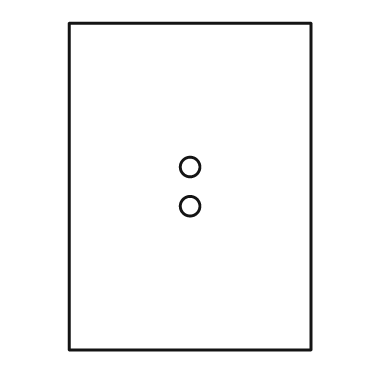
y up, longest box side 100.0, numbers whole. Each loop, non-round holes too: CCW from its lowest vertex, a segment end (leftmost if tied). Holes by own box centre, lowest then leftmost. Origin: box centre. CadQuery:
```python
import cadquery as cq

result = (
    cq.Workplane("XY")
    .moveTo(-37.0, -50.0)
    .lineTo(37.0, -50.0)
    .lineTo(37.0, 50.0)
    .lineTo(-37.0, 50.0)
    .close()
    .moveTo(0.0, -6.0)
    .circle(3.0)
    .moveTo(0.0, 6.0)
    .circle(3.0)
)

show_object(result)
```